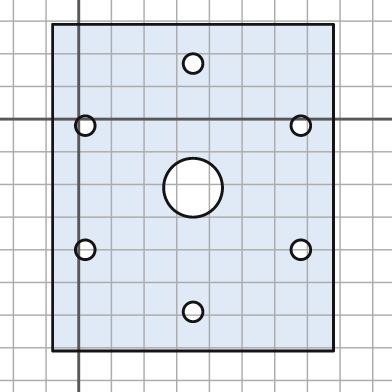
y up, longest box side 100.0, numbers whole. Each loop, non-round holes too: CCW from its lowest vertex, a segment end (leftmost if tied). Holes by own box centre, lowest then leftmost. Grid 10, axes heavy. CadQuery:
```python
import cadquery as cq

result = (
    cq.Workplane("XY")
    .moveTo(-8.0, -71.0)
    .lineTo(78.0, -71.0)
    .lineTo(78.0, 29.0)
    .lineTo(-8.0, 29.0)
    .close()
    .moveTo(35.0, -59.0)
    .circle(3.0)
    .moveTo(2.0, -40.0)
    .circle(3.0)
    .moveTo(68.0, -40.0)
    .circle(3.0)
    .moveTo(35.0, -21.0)
    .circle(9.0)
    .moveTo(2.0, -2.0)
    .circle(3.0)
    .moveTo(68.0, -2.0)
    .circle(3.0)
    .moveTo(35.0, 17.0)
    .circle(3.0)
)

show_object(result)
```